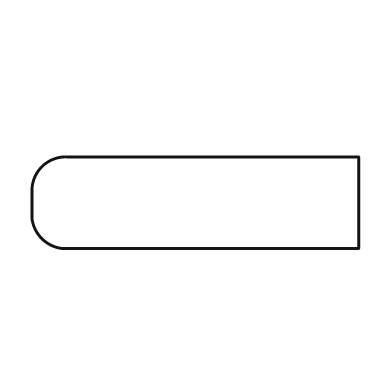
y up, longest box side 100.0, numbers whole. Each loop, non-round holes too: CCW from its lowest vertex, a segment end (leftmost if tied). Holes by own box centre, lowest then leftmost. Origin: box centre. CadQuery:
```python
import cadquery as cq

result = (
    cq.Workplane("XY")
    .moveTo(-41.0, -14.0)
    .lineTo(50.0, -14.0)
    .lineTo(50.0, 14.0)
    .lineTo(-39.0, 14.0)
    .threePointArc((-47.0, 11.0), (-50.0, 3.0))
    .lineTo(-50.0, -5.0)
    .threePointArc((-47.0, -11.0), (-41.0, -14.0))
    .close()
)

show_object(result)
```